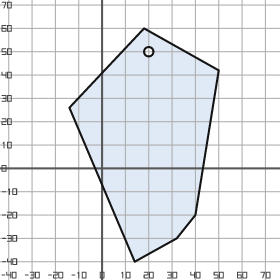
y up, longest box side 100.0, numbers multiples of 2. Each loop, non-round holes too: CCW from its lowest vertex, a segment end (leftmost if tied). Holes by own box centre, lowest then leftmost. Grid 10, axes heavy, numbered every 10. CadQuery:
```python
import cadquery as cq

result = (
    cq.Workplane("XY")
    .moveTo(14.0, -40.0)
    .lineTo(32.0, -30.0)
    .lineTo(40.0, -20.0)
    .lineTo(50.0, 42.0)
    .lineTo(18.0, 60.0)
    .lineTo(-14.0, 26.0)
    .close()
    .moveTo(20.0, 50.0)
    .circle(2.0)
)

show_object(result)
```